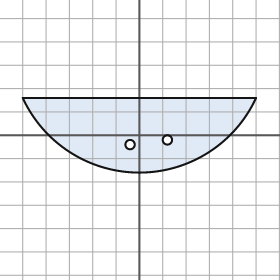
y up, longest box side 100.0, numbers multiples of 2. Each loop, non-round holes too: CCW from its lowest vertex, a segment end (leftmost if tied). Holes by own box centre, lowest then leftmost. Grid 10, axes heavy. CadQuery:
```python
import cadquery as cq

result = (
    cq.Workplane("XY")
    .moveTo(-50.0, 16.0)
    .threePointArc((0.0, -16.0), (50.0, 16.0))
    .close()
    .moveTo(-4.0, -4.0)
    .circle(2.0)
    .moveTo(12.0, -2.0)
    .circle(2.0)
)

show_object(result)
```